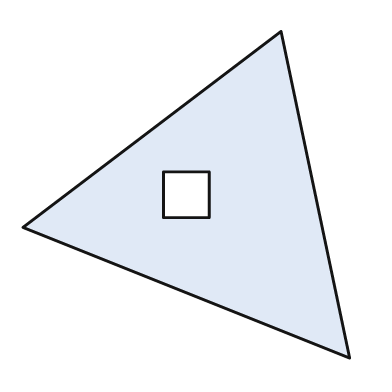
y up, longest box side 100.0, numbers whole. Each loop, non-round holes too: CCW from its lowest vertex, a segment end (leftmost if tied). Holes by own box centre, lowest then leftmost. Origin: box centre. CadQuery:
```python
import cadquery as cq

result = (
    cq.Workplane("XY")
    .moveTo(50.0, -50.0)
    .lineTo(29.0, 50.0)
    .lineTo(-50.0, -10.0)
    .close()
    .moveTo(-7.0, -7.0)
    .lineTo(7.0, -7.0)
    .lineTo(7.0, 7.0)
    .lineTo(-7.0, 7.0)
    .close()
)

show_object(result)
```